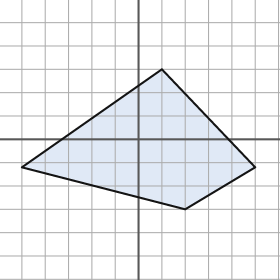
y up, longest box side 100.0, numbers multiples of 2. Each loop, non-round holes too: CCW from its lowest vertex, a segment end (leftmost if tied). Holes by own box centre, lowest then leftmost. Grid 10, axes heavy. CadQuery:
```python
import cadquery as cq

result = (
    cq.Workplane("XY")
    .moveTo(20.0, -30.0)
    .lineTo(50.0, -12.0)
    .lineTo(10.0, 30.0)
    .lineTo(-50.0, -12.0)
    .close()
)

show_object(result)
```